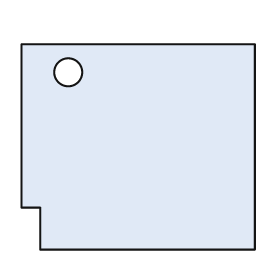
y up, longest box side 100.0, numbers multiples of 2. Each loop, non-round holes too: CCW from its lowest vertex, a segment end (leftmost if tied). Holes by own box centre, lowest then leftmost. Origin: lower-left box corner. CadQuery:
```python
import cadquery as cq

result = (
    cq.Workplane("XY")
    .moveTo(8.0, 0.0)
    .lineTo(100.0, 0.0)
    .lineTo(100.0, 88.0)
    .lineTo(0.0, 88.0)
    .lineTo(0.0, 18.0)
    .lineTo(8.0, 18.0)
    .close()
    .moveTo(20.0, 76.0)
    .circle(6.0)
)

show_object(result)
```